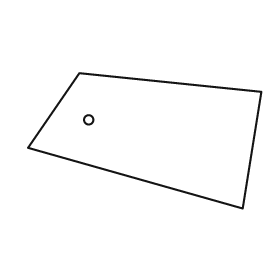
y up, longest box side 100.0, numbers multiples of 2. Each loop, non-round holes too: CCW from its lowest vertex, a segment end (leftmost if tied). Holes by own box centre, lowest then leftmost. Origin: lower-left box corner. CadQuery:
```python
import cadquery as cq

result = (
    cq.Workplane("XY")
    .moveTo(92.0, 0.0)
    .lineTo(100.0, 50.0)
    .lineTo(22.0, 58.0)
    .lineTo(0.0, 26.0)
    .close()
    .moveTo(26.0, 38.0)
    .circle(2.0)
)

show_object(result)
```